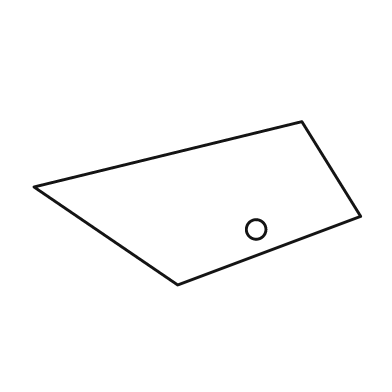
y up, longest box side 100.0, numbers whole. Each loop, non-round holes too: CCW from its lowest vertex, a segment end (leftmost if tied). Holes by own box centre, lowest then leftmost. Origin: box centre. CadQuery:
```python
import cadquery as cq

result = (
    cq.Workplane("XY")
    .moveTo(-6.0, -25.0)
    .lineTo(50.0, -4.0)
    .lineTo(32.0, 25.0)
    .lineTo(-50.0, 5.0)
    .close()
    .moveTo(18.0, -8.0)
    .circle(3.0)
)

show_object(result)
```